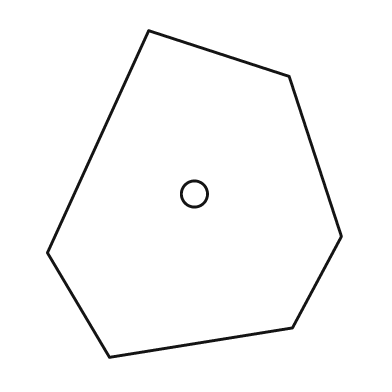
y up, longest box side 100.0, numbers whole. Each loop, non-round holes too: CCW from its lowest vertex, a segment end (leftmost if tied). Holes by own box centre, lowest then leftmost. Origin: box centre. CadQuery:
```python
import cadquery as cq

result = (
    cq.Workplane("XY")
    .moveTo(-26.0, -50.0)
    .lineTo(30.0, -41.0)
    .lineTo(45.0, -13.0)
    .lineTo(29.0, 36.0)
    .lineTo(-14.0, 50.0)
    .lineTo(-45.0, -18.0)
    .close()
    .moveTo(0.0, 0.0)
    .circle(4.0)
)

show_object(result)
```